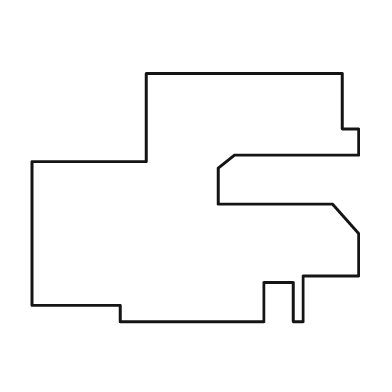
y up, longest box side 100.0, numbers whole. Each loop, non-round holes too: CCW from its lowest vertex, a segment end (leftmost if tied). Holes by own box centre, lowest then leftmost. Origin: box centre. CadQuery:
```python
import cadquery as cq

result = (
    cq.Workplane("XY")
    .moveTo(-23.0, -38.0)
    .lineTo(21.0, -38.0)
    .lineTo(21.0, -26.0)
    .lineTo(30.0, -26.0)
    .lineTo(30.0, -38.0)
    .lineTo(33.0, -38.0)
    .lineTo(33.0, -24.0)
    .lineTo(50.0, -24.0)
    .lineTo(50.0, -11.0)
    .lineTo(42.0, -2.0)
    .lineTo(7.0, -2.0)
    .lineTo(7.0, 9.0)
    .lineTo(12.0, 13.0)
    .lineTo(50.0, 13.0)
    .lineTo(50.0, 21.0)
    .lineTo(45.0, 21.0)
    .lineTo(45.0, 38.0)
    .lineTo(-15.0, 38.0)
    .lineTo(-15.0, 11.0)
    .lineTo(-50.0, 11.0)
    .lineTo(-50.0, -33.0)
    .lineTo(-23.0, -33.0)
    .close()
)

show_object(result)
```